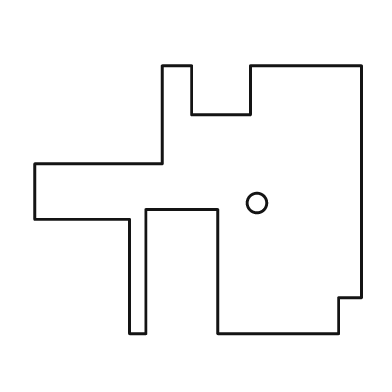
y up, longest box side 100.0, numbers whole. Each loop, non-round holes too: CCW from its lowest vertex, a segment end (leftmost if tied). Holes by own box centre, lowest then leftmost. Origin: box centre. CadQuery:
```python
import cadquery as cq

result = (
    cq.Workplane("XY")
    .moveTo(-21.0, -41.0)
    .lineTo(-16.0, -41.0)
    .lineTo(-16.0, -3.0)
    .lineTo(6.0, -3.0)
    .lineTo(6.0, -41.0)
    .lineTo(43.0, -41.0)
    .lineTo(43.0, -30.0)
    .lineTo(50.0, -30.0)
    .lineTo(50.0, 41.0)
    .lineTo(16.0, 41.0)
    .lineTo(16.0, 26.0)
    .lineTo(-2.0, 26.0)
    .lineTo(-2.0, 41.0)
    .lineTo(-11.0, 41.0)
    .lineTo(-11.0, 11.0)
    .lineTo(-50.0, 11.0)
    .lineTo(-50.0, -6.0)
    .lineTo(-21.0, -6.0)
    .close()
    .moveTo(18.0, -1.0)
    .circle(3.0)
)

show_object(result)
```